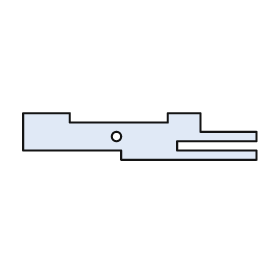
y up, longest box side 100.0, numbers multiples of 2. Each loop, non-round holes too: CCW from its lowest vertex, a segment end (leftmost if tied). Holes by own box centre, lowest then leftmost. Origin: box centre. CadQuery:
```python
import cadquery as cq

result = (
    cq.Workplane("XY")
    .moveTo(-8.0, -10.0)
    .lineTo(50.0, -10.0)
    .lineTo(50.0, -6.0)
    .lineTo(16.0, -6.0)
    .lineTo(16.0, -2.0)
    .lineTo(50.0, -2.0)
    .lineTo(50.0, 2.0)
    .lineTo(26.0, 2.0)
    .lineTo(26.0, 10.0)
    .lineTo(12.0, 10.0)
    .lineTo(12.0, 6.0)
    .lineTo(-30.0, 6.0)
    .lineTo(-30.0, 10.0)
    .lineTo(-50.0, 10.0)
    .lineTo(-50.0, -6.0)
    .lineTo(-8.0, -6.0)
    .close()
    .moveTo(-10.0, 0.0)
    .circle(2.0)
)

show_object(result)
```